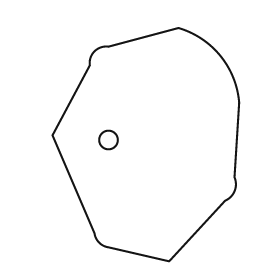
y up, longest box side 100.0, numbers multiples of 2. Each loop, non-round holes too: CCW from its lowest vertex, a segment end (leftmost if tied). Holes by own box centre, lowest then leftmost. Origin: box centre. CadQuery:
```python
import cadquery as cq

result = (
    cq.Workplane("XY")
    .moveTo(10.0, -50.0)
    .lineTo(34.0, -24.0)
    .threePointArc((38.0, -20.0), (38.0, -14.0))
    .lineTo(40.0, 18.0)
    .threePointArc((32.0, 38.0), (14.0, 50.0))
    .lineTo(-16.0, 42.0)
    .threePointArc((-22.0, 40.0), (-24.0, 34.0))
    .lineTo(-40.0, 4.0)
    .lineTo(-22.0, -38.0)
    .threePointArc((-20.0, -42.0), (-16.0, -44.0))
    .close()
    .moveTo(-16.0, 2.0)
    .circle(4.0)
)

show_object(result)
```